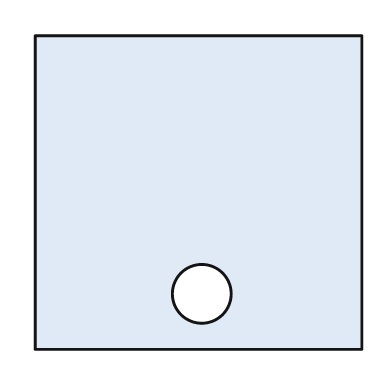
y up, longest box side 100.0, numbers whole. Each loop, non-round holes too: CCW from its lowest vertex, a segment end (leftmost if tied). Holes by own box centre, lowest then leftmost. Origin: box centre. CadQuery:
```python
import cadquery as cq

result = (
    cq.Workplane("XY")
    .moveTo(-50.0, -48.0)
    .lineTo(50.0, -48.0)
    .lineTo(50.0, 48.0)
    .lineTo(-50.0, 48.0)
    .close()
    .moveTo(1.0, -31.0)
    .circle(9.0)
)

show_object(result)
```